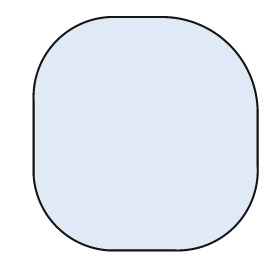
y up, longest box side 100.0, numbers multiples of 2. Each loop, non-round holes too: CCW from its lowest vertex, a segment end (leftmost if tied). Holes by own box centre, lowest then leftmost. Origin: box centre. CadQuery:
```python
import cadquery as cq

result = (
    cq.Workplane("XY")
    .moveTo(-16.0, -50.0)
    .lineTo(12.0, -50.0)
    .threePointArc((38.0, -40.0), (48.0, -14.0))
    .lineTo(48.0, 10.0)
    .threePointArc((36.0, 38.0), (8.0, 50.0))
    .lineTo(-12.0, 50.0)
    .threePointArc((-38.0, 40.0), (-48.0, 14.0))
    .lineTo(-48.0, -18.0)
    .threePointArc((-38.0, -40.0), (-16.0, -50.0))
    .close()
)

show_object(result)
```